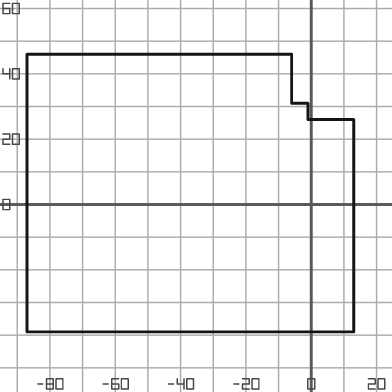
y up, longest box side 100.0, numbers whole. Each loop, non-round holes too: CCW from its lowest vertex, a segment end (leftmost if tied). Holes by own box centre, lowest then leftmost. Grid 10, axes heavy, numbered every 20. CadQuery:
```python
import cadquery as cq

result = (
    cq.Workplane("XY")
    .moveTo(-87.0, -39.0)
    .lineTo(13.0, -39.0)
    .lineTo(13.0, 26.0)
    .lineTo(-1.0, 26.0)
    .lineTo(-1.0, 31.0)
    .lineTo(-6.0, 31.0)
    .lineTo(-6.0, 46.0)
    .lineTo(-87.0, 46.0)
    .close()
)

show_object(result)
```